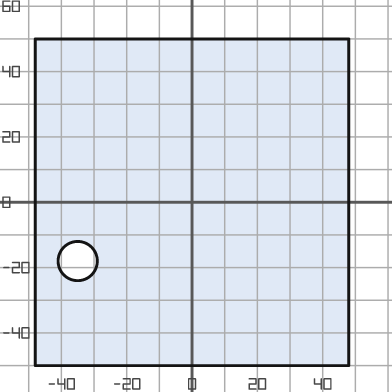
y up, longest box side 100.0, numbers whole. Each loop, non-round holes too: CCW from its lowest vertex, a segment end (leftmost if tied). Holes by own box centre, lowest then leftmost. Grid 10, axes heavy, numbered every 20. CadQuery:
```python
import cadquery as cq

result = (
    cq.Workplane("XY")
    .moveTo(-48.0, -50.0)
    .lineTo(48.0, -50.0)
    .lineTo(48.0, 50.0)
    .lineTo(-48.0, 50.0)
    .close()
    .moveTo(-35.0, -18.0)
    .circle(6.0)
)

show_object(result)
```